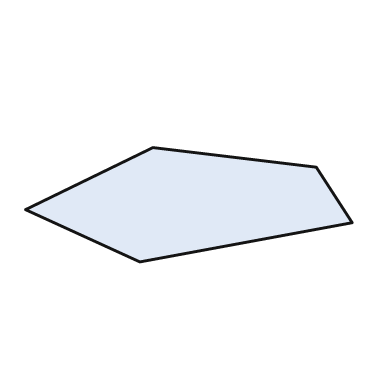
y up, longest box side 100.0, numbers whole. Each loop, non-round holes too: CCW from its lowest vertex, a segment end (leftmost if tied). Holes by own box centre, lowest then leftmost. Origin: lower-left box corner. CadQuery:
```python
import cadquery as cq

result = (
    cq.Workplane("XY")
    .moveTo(35.0, 0.0)
    .lineTo(100.0, 12.0)
    .lineTo(89.0, 29.0)
    .lineTo(39.0, 35.0)
    .lineTo(0.0, 16.0)
    .close()
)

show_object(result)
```